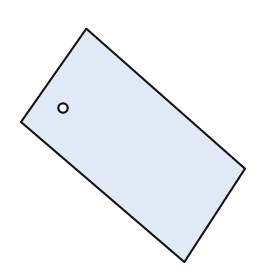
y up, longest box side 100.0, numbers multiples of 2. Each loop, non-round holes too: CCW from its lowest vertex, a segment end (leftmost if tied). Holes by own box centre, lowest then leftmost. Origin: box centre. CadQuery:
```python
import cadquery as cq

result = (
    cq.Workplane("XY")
    .moveTo(22.0, -50.0)
    .lineTo(48.0, -10.0)
    .lineTo(-20.0, 50.0)
    .lineTo(-48.0, 10.0)
    .close()
    .moveTo(-30.0, 16.0)
    .circle(2.0)
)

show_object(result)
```